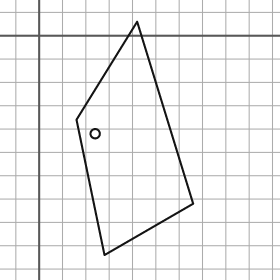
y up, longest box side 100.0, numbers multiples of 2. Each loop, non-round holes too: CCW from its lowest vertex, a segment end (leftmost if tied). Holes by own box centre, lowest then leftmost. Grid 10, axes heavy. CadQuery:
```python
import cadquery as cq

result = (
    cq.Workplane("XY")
    .moveTo(28.0, -94.0)
    .lineTo(66.0, -72.0)
    .lineTo(42.0, 6.0)
    .lineTo(16.0, -36.0)
    .close()
    .moveTo(24.0, -42.0)
    .circle(2.0)
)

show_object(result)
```